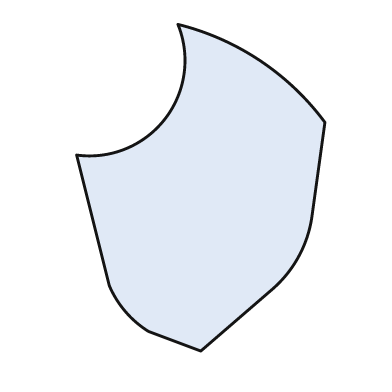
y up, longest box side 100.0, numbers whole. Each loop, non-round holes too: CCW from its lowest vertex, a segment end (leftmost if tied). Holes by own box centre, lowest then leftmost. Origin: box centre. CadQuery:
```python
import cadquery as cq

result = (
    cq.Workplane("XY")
    .moveTo(0.0, -50.0)
    .lineTo(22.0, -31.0)
    .threePointArc((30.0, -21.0), (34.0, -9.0))
    .lineTo(38.0, 20.0)
    .threePointArc((18.0, 39.0), (-7.0, 50.0))
    .threePointArc((-11.0, 21.0), (-38.0, 10.0))
    .lineTo(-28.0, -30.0)
    .threePointArc((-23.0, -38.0), (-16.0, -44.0))
    .close()
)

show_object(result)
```